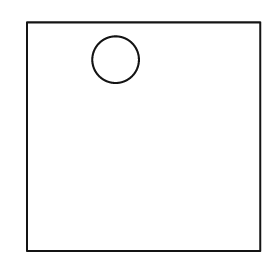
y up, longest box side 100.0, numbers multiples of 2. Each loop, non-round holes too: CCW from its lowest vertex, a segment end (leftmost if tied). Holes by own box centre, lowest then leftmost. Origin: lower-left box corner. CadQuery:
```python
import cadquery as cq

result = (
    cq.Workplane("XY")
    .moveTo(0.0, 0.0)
    .lineTo(100.0, 0.0)
    .lineTo(100.0, 98.0)
    .lineTo(0.0, 98.0)
    .close()
    .moveTo(38.0, 82.0)
    .circle(10.0)
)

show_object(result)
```